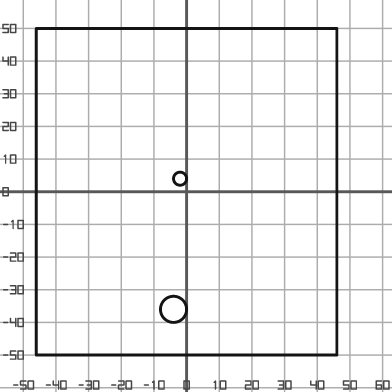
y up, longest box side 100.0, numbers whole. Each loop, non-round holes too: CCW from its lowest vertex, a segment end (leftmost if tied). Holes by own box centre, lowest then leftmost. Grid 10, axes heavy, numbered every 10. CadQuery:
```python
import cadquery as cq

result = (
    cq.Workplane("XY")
    .moveTo(-46.0, -50.0)
    .lineTo(46.0, -50.0)
    .lineTo(46.0, 50.0)
    .lineTo(-46.0, 50.0)
    .close()
    .moveTo(-4.0, -36.0)
    .circle(4.0)
    .moveTo(-2.0, 4.0)
    .circle(2.0)
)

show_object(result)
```